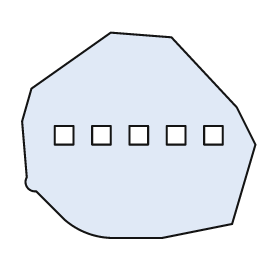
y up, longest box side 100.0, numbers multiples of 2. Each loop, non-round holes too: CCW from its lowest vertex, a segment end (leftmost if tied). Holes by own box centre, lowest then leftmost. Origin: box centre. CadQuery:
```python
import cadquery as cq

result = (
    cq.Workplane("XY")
    .moveTo(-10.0, -44.0)
    .lineTo(10.0, -44.0)
    .lineTo(40.0, -38.0)
    .lineTo(50.0, -4.0)
    .lineTo(42.0, 12.0)
    .lineTo(14.0, 42.0)
    .lineTo(-12.0, 44.0)
    .lineTo(-46.0, 20.0)
    .lineTo(-50.0, 6.0)
    .lineTo(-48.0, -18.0)
    .threePointArc((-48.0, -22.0), (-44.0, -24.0))
    .lineTo(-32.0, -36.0)
    .threePointArc((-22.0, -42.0), (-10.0, -44.0))
    .close()
    .moveTo(-36.0, -4.0)
    .lineTo(-28.0, -4.0)
    .lineTo(-28.0, 4.0)
    .lineTo(-36.0, 4.0)
    .close()
    .moveTo(-20.0, -4.0)
    .lineTo(-12.0, -4.0)
    .lineTo(-12.0, 4.0)
    .lineTo(-20.0, 4.0)
    .close()
    .moveTo(-4.0, -4.0)
    .lineTo(4.0, -4.0)
    .lineTo(4.0, 4.0)
    .lineTo(-4.0, 4.0)
    .close()
    .moveTo(12.0, -4.0)
    .lineTo(20.0, -4.0)
    .lineTo(20.0, 4.0)
    .lineTo(12.0, 4.0)
    .close()
    .moveTo(28.0, -4.0)
    .lineTo(36.0, -4.0)
    .lineTo(36.0, 4.0)
    .lineTo(28.0, 4.0)
    .close()
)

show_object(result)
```